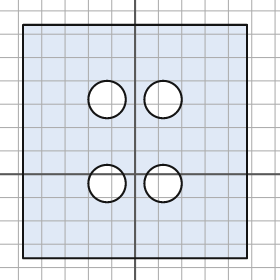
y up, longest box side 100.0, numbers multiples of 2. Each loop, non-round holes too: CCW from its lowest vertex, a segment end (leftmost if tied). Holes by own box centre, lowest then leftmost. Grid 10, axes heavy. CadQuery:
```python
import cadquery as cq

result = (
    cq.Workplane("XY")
    .moveTo(-48.0, -36.0)
    .lineTo(48.0, -36.0)
    .lineTo(48.0, 64.0)
    .lineTo(-48.0, 64.0)
    .close()
    .moveTo(-12.0, -4.0)
    .circle(8.0)
    .moveTo(12.0, -4.0)
    .circle(8.0)
    .moveTo(-12.0, 32.0)
    .circle(8.0)
    .moveTo(12.0, 32.0)
    .circle(8.0)
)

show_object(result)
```